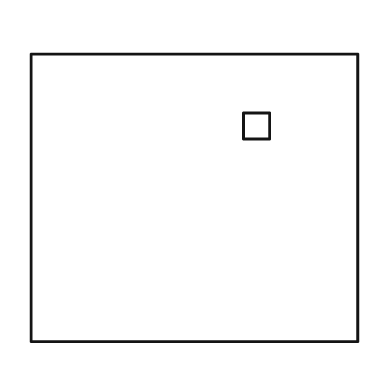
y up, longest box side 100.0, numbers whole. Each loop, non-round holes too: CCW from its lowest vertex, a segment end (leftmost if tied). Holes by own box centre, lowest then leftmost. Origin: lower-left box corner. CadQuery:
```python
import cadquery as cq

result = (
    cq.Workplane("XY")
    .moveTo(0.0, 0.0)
    .lineTo(100.0, 0.0)
    .lineTo(100.0, 88.0)
    .lineTo(0.0, 88.0)
    .close()
    .moveTo(65.0, 62.0)
    .lineTo(73.0, 62.0)
    .lineTo(73.0, 70.0)
    .lineTo(65.0, 70.0)
    .close()
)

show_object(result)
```